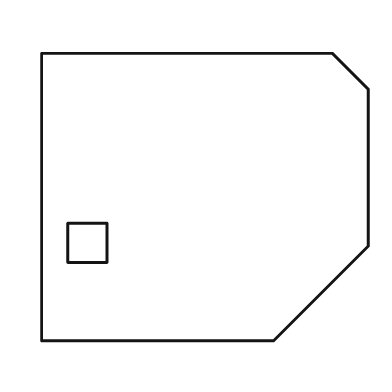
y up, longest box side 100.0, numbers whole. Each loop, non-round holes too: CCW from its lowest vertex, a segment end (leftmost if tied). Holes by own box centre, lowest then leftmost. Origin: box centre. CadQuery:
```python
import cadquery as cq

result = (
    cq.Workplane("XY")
    .moveTo(-50.0, -44.0)
    .lineTo(21.0, -44.0)
    .lineTo(50.0, -15.0)
    .lineTo(50.0, 33.0)
    .lineTo(39.0, 44.0)
    .lineTo(-50.0, 44.0)
    .close()
    .moveTo(-42.0, -20.0)
    .lineTo(-30.0, -20.0)
    .lineTo(-30.0, -8.0)
    .lineTo(-42.0, -8.0)
    .close()
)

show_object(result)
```